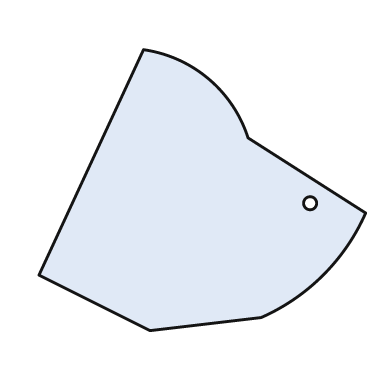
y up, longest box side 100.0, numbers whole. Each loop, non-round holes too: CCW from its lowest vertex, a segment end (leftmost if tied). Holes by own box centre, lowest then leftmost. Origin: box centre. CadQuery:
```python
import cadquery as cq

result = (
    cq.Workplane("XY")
    .moveTo(-16.0, -43.0)
    .lineTo(18.0, -39.0)
    .threePointArc((37.0, -26.0), (50.0, -7.0))
    .lineTo(14.0, 16.0)
    .threePointArc((2.0, 34.0), (-18.0, 43.0))
    .lineTo(-50.0, -26.0)
    .close()
    .moveTo(33.0, -4.0)
    .circle(2.0)
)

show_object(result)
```